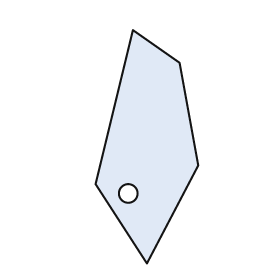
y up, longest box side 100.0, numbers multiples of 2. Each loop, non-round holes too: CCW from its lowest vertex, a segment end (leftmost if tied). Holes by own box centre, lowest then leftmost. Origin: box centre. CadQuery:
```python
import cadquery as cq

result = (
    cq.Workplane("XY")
    .moveTo(0.0, -50.0)
    .lineTo(22.0, -8.0)
    .lineTo(14.0, 36.0)
    .lineTo(-6.0, 50.0)
    .lineTo(-22.0, -16.0)
    .close()
    .moveTo(-8.0, -20.0)
    .circle(4.0)
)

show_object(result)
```